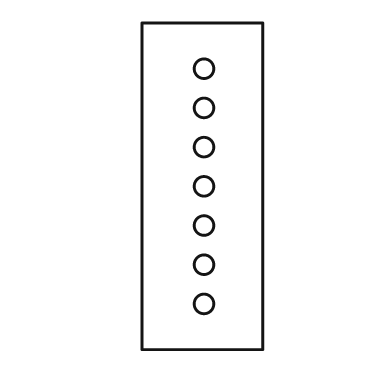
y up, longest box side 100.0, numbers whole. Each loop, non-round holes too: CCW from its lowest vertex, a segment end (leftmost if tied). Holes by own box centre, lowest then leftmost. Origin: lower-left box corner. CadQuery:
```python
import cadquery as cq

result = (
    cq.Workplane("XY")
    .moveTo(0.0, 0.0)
    .lineTo(37.0, 0.0)
    .lineTo(37.0, 100.0)
    .lineTo(0.0, 100.0)
    .close()
    .moveTo(19.0, 14.0)
    .circle(3.0)
    .moveTo(19.0, 26.0)
    .circle(3.0)
    .moveTo(19.0, 38.0)
    .circle(3.0)
    .moveTo(19.0, 50.0)
    .circle(3.0)
    .moveTo(19.0, 62.0)
    .circle(3.0)
    .moveTo(19.0, 74.0)
    .circle(3.0)
    .moveTo(19.0, 86.0)
    .circle(3.0)
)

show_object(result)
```